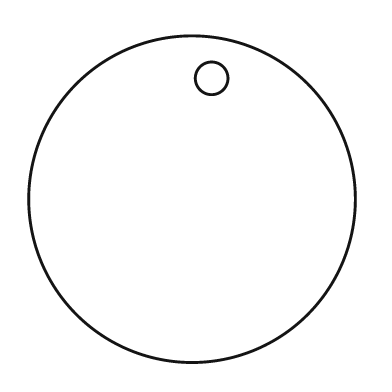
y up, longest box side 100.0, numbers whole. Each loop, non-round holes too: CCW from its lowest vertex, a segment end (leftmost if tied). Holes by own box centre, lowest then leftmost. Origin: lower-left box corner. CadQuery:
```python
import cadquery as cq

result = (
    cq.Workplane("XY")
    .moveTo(50.0, 50.0)
    .circle(50.0)
    .moveTo(56.0, 87.0)
    .circle(5.0)
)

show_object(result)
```